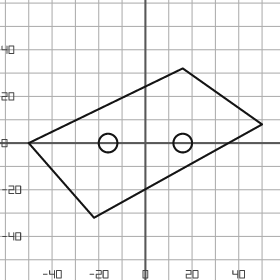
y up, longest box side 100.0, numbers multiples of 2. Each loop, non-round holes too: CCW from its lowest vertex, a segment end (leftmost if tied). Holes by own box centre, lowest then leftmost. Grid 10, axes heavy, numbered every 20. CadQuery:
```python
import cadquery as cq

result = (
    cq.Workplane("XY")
    .moveTo(-22.0, -32.0)
    .lineTo(50.0, 8.0)
    .lineTo(16.0, 32.0)
    .lineTo(-50.0, 0.0)
    .close()
    .moveTo(-16.0, 0.0)
    .circle(4.0)
    .moveTo(16.0, 0.0)
    .circle(4.0)
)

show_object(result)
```